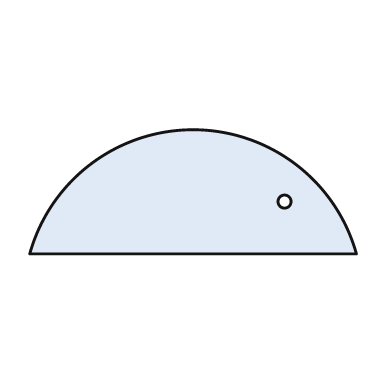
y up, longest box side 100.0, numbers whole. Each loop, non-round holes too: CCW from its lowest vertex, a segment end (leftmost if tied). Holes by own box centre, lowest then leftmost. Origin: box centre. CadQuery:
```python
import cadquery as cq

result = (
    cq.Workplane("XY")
    .moveTo(-50.0, -19.0)
    .lineTo(50.0, -19.0)
    .threePointArc((0.0, 19.0), (-50.0, -19.0))
    .close()
    .moveTo(28.0, -3.0)
    .circle(2.0)
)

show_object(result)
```